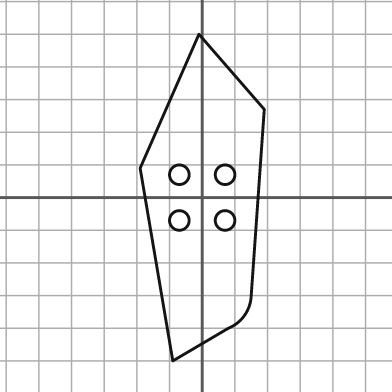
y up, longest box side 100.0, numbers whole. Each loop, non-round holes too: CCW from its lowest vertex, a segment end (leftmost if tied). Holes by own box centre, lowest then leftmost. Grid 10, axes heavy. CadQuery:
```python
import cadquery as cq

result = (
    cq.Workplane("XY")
    .moveTo(-9.0, -50.0)
    .lineTo(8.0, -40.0)
    .threePointArc((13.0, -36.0), (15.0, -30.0))
    .lineTo(19.0, 27.0)
    .lineTo(-1.0, 50.0)
    .lineTo(-19.0, 9.0)
    .close()
    .moveTo(-7.0, -7.0)
    .circle(3.0)
    .moveTo(7.0, -7.0)
    .circle(3.0)
    .moveTo(-7.0, 7.0)
    .circle(3.0)
    .moveTo(7.0, 7.0)
    .circle(3.0)
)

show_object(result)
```